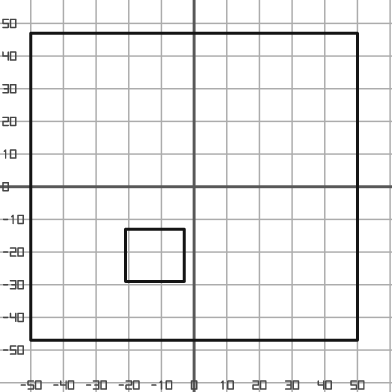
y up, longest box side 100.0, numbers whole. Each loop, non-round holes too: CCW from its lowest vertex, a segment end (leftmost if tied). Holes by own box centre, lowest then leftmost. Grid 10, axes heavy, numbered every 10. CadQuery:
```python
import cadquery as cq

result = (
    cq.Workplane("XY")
    .moveTo(-50.0, -47.0)
    .lineTo(50.0, -47.0)
    .lineTo(50.0, 47.0)
    .lineTo(-50.0, 47.0)
    .close()
    .moveTo(-21.0, -29.0)
    .lineTo(-3.0, -29.0)
    .lineTo(-3.0, -13.0)
    .lineTo(-21.0, -13.0)
    .close()
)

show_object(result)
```